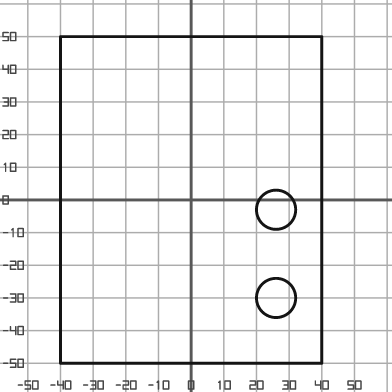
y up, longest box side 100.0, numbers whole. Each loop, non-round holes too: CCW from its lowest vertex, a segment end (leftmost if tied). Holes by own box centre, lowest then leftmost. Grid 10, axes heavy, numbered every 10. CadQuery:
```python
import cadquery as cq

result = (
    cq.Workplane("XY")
    .moveTo(-40.0, -50.0)
    .lineTo(40.0, -50.0)
    .lineTo(40.0, 50.0)
    .lineTo(-40.0, 50.0)
    .close()
    .moveTo(26.0, -30.0)
    .circle(6.0)
    .moveTo(26.0, -3.0)
    .circle(6.0)
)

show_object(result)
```